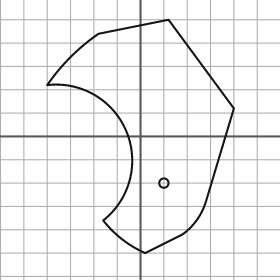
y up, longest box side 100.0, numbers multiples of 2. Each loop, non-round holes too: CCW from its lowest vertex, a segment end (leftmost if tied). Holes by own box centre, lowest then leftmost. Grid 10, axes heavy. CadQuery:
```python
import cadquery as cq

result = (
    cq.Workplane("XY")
    .moveTo(2.0, -50.0)
    .lineTo(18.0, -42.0)
    .threePointArc((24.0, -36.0), (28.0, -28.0))
    .lineTo(40.0, 12.0)
    .lineTo(12.0, 50.0)
    .lineTo(-18.0, 44.0)
    .threePointArc((-30.0, 34.0), (-40.0, 22.0))
    .threePointArc((-6.0, 2.0), (-16.0, -36.0))
    .threePointArc((-8.0, -44.0), (2.0, -50.0))
    .close()
    .moveTo(10.0, -20.0)
    .circle(2.0)
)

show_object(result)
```